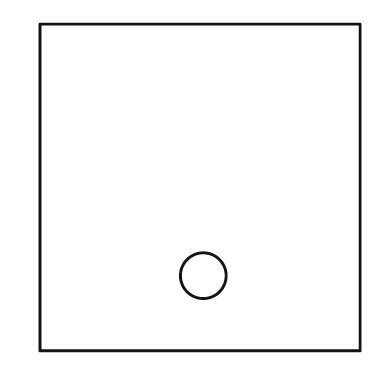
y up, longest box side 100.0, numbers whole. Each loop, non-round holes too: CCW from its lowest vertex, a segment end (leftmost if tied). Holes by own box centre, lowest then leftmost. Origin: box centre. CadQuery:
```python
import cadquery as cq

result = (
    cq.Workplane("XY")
    .moveTo(-49.0, -50.0)
    .lineTo(49.0, -50.0)
    .lineTo(49.0, 50.0)
    .lineTo(-49.0, 50.0)
    .close()
    .moveTo(1.0, -27.0)
    .circle(7.0)
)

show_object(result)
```